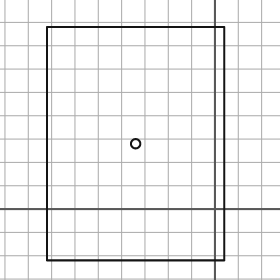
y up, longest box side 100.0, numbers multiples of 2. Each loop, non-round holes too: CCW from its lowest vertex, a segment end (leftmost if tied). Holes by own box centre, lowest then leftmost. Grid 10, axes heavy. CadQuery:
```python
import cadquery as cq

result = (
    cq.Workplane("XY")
    .moveTo(-72.0, -22.0)
    .lineTo(4.0, -22.0)
    .lineTo(4.0, 78.0)
    .lineTo(-72.0, 78.0)
    .close()
    .moveTo(-34.0, 28.0)
    .circle(2.0)
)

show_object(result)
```